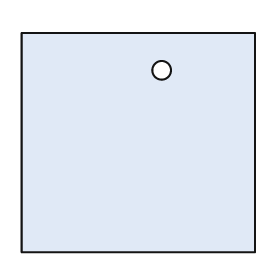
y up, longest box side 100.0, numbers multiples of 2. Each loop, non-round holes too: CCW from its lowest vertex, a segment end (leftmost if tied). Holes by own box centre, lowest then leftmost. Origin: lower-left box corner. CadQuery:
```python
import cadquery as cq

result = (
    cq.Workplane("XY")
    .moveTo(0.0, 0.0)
    .lineTo(100.0, 0.0)
    .lineTo(100.0, 94.0)
    .lineTo(0.0, 94.0)
    .close()
    .moveTo(60.0, 78.0)
    .circle(4.0)
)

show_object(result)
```